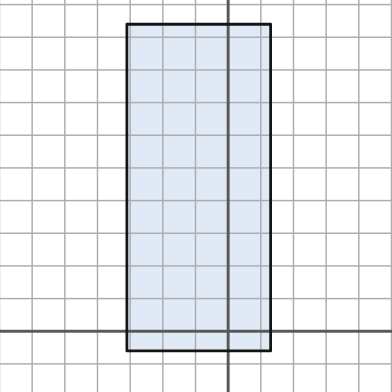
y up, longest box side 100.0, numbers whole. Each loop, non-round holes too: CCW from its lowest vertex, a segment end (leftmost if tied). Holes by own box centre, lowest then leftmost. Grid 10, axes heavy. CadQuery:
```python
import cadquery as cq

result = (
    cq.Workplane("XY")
    .moveTo(-31.0, -6.0)
    .lineTo(13.0, -6.0)
    .lineTo(13.0, 94.0)
    .lineTo(-31.0, 94.0)
    .close()
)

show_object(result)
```